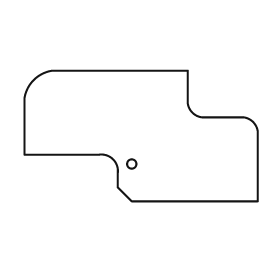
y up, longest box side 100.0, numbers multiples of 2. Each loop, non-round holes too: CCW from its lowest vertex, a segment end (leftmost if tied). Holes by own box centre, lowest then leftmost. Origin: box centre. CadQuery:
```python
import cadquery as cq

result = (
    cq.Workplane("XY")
    .moveTo(-4.0, -28.0)
    .lineTo(50.0, -28.0)
    .lineTo(50.0, 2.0)
    .threePointArc((48.0, 6.0), (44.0, 8.0))
    .lineTo(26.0, 8.0)
    .threePointArc((22.0, 10.0), (20.0, 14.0))
    .lineTo(20.0, 28.0)
    .lineTo(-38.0, 28.0)
    .threePointArc((-46.0, 24.0), (-50.0, 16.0))
    .lineTo(-50.0, -8.0)
    .lineTo(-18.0, -8.0)
    .threePointArc((-12.0, -10.0), (-10.0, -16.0))
    .lineTo(-10.0, -22.0)
    .close()
    .moveTo(-4.0, -12.0)
    .circle(2.0)
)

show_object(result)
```